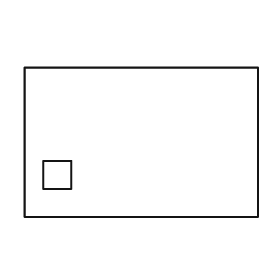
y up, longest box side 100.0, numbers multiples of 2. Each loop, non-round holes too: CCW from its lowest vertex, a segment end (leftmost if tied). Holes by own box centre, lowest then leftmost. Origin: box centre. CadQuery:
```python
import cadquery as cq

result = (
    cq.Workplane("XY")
    .moveTo(-50.0, -32.0)
    .lineTo(50.0, -32.0)
    .lineTo(50.0, 32.0)
    .lineTo(-50.0, 32.0)
    .close()
    .moveTo(-42.0, -20.0)
    .lineTo(-30.0, -20.0)
    .lineTo(-30.0, -8.0)
    .lineTo(-42.0, -8.0)
    .close()
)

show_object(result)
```